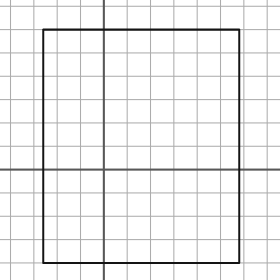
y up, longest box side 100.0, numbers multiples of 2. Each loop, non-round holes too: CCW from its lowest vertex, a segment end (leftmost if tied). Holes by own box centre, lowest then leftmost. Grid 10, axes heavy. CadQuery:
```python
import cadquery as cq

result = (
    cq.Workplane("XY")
    .moveTo(-26.0, -40.0)
    .lineTo(58.0, -40.0)
    .lineTo(58.0, 60.0)
    .lineTo(-26.0, 60.0)
    .close()
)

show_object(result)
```